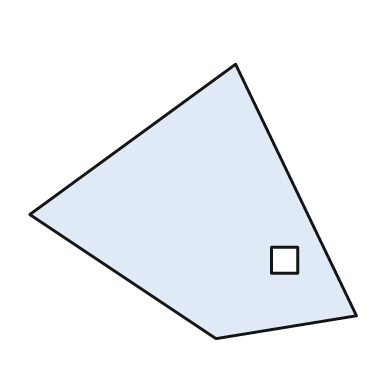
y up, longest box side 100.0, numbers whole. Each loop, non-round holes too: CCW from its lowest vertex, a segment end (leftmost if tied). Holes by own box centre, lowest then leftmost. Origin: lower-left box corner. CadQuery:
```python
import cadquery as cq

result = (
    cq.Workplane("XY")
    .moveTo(57.0, 0.0)
    .lineTo(100.0, 7.0)
    .lineTo(63.0, 84.0)
    .lineTo(0.0, 38.0)
    .close()
    .moveTo(74.0, 20.0)
    .lineTo(82.0, 20.0)
    .lineTo(82.0, 28.0)
    .lineTo(74.0, 28.0)
    .close()
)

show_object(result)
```